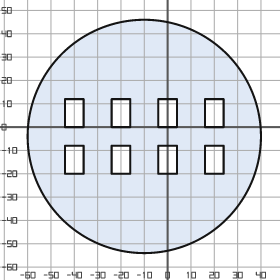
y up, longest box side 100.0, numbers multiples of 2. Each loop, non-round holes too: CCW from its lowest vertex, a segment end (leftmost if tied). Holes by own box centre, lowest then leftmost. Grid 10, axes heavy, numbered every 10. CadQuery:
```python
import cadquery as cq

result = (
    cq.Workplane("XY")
    .moveTo(-10.0, -4.0)
    .circle(50.0)
    .moveTo(-44.0, -20.0)
    .lineTo(-36.0, -20.0)
    .lineTo(-36.0, -8.0)
    .lineTo(-44.0, -8.0)
    .close()
    .moveTo(-24.0, -20.0)
    .lineTo(-16.0, -20.0)
    .lineTo(-16.0, -8.0)
    .lineTo(-24.0, -8.0)
    .close()
    .moveTo(-4.0, -20.0)
    .lineTo(4.0, -20.0)
    .lineTo(4.0, -8.0)
    .lineTo(-4.0, -8.0)
    .close()
    .moveTo(16.0, -20.0)
    .lineTo(24.0, -20.0)
    .lineTo(24.0, -8.0)
    .lineTo(16.0, -8.0)
    .close()
    .moveTo(-44.0, 0.0)
    .lineTo(-36.0, 0.0)
    .lineTo(-36.0, 12.0)
    .lineTo(-44.0, 12.0)
    .close()
    .moveTo(-24.0, 0.0)
    .lineTo(-16.0, 0.0)
    .lineTo(-16.0, 12.0)
    .lineTo(-24.0, 12.0)
    .close()
    .moveTo(-4.0, 0.0)
    .lineTo(4.0, 0.0)
    .lineTo(4.0, 12.0)
    .lineTo(-4.0, 12.0)
    .close()
    .moveTo(16.0, 0.0)
    .lineTo(24.0, 0.0)
    .lineTo(24.0, 12.0)
    .lineTo(16.0, 12.0)
    .close()
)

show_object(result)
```